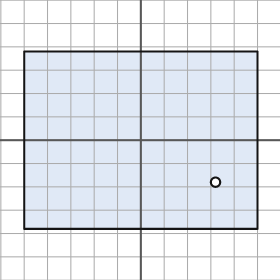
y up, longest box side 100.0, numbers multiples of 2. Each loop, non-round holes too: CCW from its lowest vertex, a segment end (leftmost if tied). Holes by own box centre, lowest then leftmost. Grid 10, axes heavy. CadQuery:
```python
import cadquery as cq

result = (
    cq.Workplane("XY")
    .moveTo(-50.0, -38.0)
    .lineTo(50.0, -38.0)
    .lineTo(50.0, 38.0)
    .lineTo(-50.0, 38.0)
    .close()
    .moveTo(32.0, -18.0)
    .circle(2.0)
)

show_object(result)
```